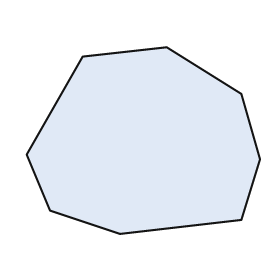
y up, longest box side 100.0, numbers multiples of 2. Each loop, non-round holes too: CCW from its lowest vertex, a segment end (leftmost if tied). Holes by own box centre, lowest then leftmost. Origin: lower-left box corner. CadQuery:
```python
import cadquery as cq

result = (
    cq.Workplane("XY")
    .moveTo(40.0, 0.0)
    .lineTo(92.0, 6.0)
    .lineTo(100.0, 32.0)
    .lineTo(92.0, 60.0)
    .lineTo(60.0, 80.0)
    .lineTo(24.0, 76.0)
    .lineTo(0.0, 34.0)
    .lineTo(10.0, 10.0)
    .close()
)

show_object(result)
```